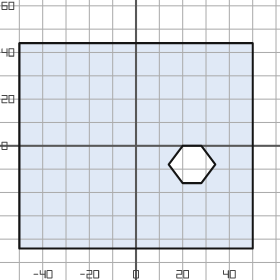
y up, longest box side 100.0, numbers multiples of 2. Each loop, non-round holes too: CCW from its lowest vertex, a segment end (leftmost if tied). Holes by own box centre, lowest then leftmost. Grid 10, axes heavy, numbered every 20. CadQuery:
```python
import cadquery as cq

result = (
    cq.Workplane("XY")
    .moveTo(-50.0, -44.0)
    .lineTo(50.0, -44.0)
    .lineTo(50.0, 44.0)
    .lineTo(-50.0, 44.0)
    .close()
    .moveTo(20.0, -16.0)
    .lineTo(28.0, -16.0)
    .lineTo(34.0, -8.0)
    .lineTo(28.0, 0.0)
    .lineTo(20.0, 0.0)
    .lineTo(14.0, -8.0)
    .close()
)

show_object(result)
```